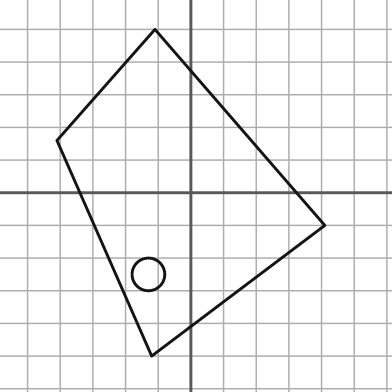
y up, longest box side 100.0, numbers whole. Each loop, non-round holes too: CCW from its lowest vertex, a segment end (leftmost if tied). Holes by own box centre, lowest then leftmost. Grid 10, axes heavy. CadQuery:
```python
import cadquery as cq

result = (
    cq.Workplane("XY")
    .moveTo(-12.0, -50.0)
    .lineTo(41.0, -10.0)
    .lineTo(-11.0, 50.0)
    .lineTo(-41.0, 16.0)
    .close()
    .moveTo(-13.0, -25.0)
    .circle(5.0)
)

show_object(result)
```